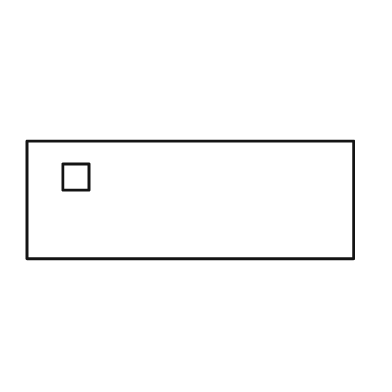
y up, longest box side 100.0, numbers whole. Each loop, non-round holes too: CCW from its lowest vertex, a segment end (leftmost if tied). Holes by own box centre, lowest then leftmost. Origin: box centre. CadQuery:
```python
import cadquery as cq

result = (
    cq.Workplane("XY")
    .moveTo(-50.0, -18.0)
    .lineTo(50.0, -18.0)
    .lineTo(50.0, 18.0)
    .lineTo(-50.0, 18.0)
    .close()
    .moveTo(-39.0, 3.0)
    .lineTo(-31.0, 3.0)
    .lineTo(-31.0, 11.0)
    .lineTo(-39.0, 11.0)
    .close()
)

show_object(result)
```